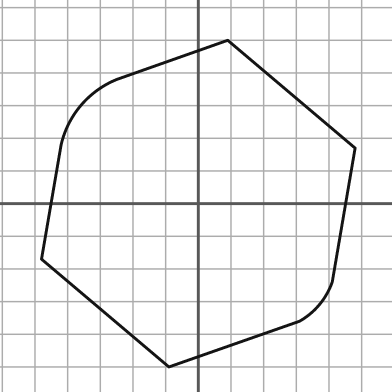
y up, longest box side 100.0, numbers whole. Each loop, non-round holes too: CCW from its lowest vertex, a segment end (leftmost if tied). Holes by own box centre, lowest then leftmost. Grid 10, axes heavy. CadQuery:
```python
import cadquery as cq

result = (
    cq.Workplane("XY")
    .moveTo(-9.0, -50.0)
    .lineTo(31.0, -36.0)
    .threePointArc((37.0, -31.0), (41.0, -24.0))
    .lineTo(48.0, 17.0)
    .lineTo(9.0, 50.0)
    .lineTo(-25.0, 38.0)
    .threePointArc((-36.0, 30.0), (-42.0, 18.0))
    .lineTo(-48.0, -17.0)
    .close()
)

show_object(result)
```